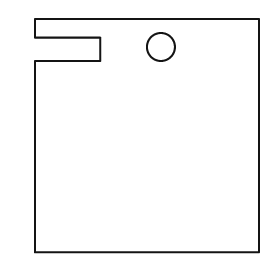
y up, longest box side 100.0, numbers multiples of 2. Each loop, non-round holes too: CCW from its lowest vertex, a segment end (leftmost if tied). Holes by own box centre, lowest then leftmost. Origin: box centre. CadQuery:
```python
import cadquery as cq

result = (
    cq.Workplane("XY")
    .moveTo(-48.0, -50.0)
    .lineTo(48.0, -50.0)
    .lineTo(48.0, 50.0)
    .lineTo(-48.0, 50.0)
    .lineTo(-48.0, 42.0)
    .lineTo(-20.0, 42.0)
    .lineTo(-20.0, 32.0)
    .lineTo(-48.0, 32.0)
    .close()
    .moveTo(6.0, 38.0)
    .circle(6.0)
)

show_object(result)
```